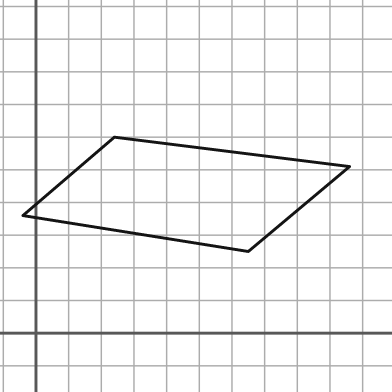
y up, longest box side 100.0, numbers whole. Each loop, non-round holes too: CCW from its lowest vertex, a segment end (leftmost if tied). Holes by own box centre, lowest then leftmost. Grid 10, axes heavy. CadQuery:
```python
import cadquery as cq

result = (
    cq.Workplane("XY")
    .moveTo(65.0, 25.0)
    .lineTo(96.0, 51.0)
    .lineTo(24.0, 60.0)
    .lineTo(-4.0, 36.0)
    .close()
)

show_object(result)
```